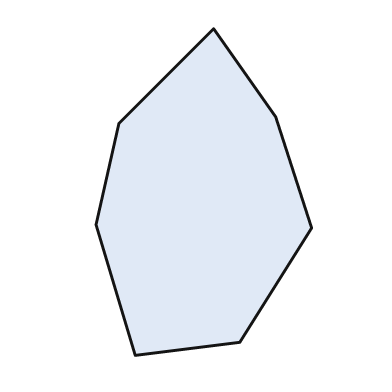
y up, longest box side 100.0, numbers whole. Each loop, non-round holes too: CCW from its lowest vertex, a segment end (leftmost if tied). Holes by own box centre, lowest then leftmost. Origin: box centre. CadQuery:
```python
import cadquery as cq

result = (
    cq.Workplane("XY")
    .moveTo(-21.0, -50.0)
    .lineTo(11.0, -46.0)
    .lineTo(33.0, -11.0)
    .lineTo(22.0, 23.0)
    .lineTo(3.0, 50.0)
    .lineTo(-26.0, 21.0)
    .lineTo(-33.0, -10.0)
    .close()
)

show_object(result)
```